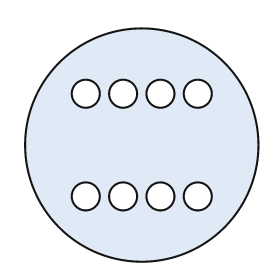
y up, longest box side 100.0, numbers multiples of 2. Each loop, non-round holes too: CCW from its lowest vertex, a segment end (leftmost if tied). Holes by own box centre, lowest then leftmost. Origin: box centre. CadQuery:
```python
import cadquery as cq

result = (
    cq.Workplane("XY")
    .moveTo(0.0, 0.0)
    .circle(50.0)
    .moveTo(-24.0, -22.0)
    .circle(6.0)
    .moveTo(-8.0, -22.0)
    .circle(6.0)
    .moveTo(8.0, -22.0)
    .circle(6.0)
    .moveTo(24.0, -22.0)
    .circle(6.0)
    .moveTo(-24.0, 22.0)
    .circle(6.0)
    .moveTo(-8.0, 22.0)
    .circle(6.0)
    .moveTo(8.0, 22.0)
    .circle(6.0)
    .moveTo(24.0, 22.0)
    .circle(6.0)
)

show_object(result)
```